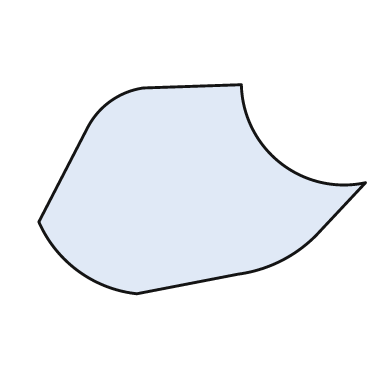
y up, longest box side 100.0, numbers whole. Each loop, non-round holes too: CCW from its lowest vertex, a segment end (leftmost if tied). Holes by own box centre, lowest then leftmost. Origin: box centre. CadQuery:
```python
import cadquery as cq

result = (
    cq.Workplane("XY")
    .moveTo(-20.0, -32.0)
    .lineTo(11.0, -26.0)
    .threePointArc((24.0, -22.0), (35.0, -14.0))
    .lineTo(50.0, 2.0)
    .threePointArc((24.0, 8.0), (12.0, 32.0))
    .lineTo(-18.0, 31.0)
    .threePointArc((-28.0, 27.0), (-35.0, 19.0))
    .lineTo(-50.0, -10.0)
    .threePointArc((-38.0, -25.0), (-20.0, -32.0))
    .close()
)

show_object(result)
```